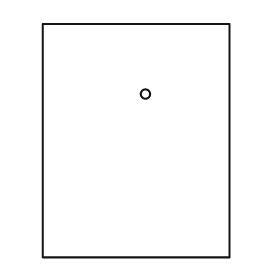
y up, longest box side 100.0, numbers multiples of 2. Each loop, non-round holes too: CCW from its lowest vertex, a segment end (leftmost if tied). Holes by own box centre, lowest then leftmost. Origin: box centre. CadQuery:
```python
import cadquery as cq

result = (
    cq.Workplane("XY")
    .moveTo(-40.0, -50.0)
    .lineTo(40.0, -50.0)
    .lineTo(40.0, 50.0)
    .lineTo(-40.0, 50.0)
    .close()
    .moveTo(4.0, 20.0)
    .circle(2.0)
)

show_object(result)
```